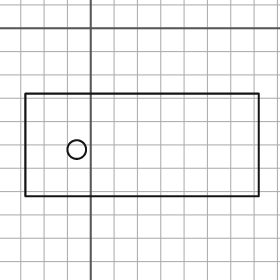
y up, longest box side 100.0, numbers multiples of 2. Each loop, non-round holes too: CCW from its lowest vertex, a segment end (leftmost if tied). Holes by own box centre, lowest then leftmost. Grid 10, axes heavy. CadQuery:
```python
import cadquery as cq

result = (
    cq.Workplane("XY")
    .moveTo(-28.0, -72.0)
    .lineTo(72.0, -72.0)
    .lineTo(72.0, -28.0)
    .lineTo(-28.0, -28.0)
    .close()
    .moveTo(-6.0, -52.0)
    .circle(4.0)
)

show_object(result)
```